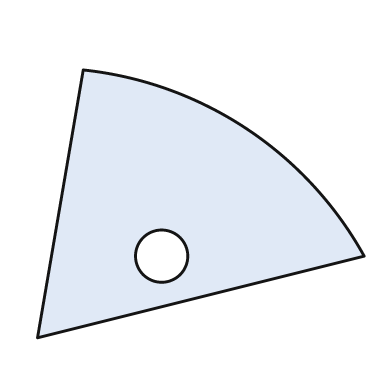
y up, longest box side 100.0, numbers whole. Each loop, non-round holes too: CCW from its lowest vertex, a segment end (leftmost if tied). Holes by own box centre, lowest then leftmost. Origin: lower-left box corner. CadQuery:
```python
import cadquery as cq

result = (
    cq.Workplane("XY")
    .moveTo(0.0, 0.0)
    .lineTo(100.0, 25.0)
    .threePointArc((64.0, 64.0), (14.0, 82.0))
    .close()
    .moveTo(38.0, 25.0)
    .circle(8.0)
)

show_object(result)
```